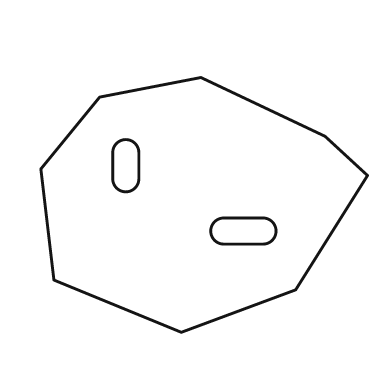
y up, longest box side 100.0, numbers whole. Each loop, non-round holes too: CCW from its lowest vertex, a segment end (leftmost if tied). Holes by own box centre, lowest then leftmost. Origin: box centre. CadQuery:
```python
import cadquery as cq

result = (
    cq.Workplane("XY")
    .moveTo(-7.0, -39.0)
    .lineTo(28.0, -26.0)
    .lineTo(50.0, 9.0)
    .lineTo(37.0, 21.0)
    .lineTo(-1.0, 39.0)
    .lineTo(-32.0, 33.0)
    .lineTo(-50.0, 11.0)
    .lineTo(-46.0, -23.0)
    .close()
    .moveTo(6.0, -12.0)
    .lineTo(18.0, -12.0)
    .threePointArc((22.0, -8.0), (18.0, -4.0))
    .lineTo(6.0, -4.0)
    .threePointArc((2.0, -8.0), (6.0, -12.0))
    .close()
    .moveTo(-28.0, 8.0)
    .threePointArc((-24.0, 4.0), (-20.0, 8.0))
    .lineTo(-20.0, 16.0)
    .threePointArc((-24.0, 20.0), (-28.0, 16.0))
    .close()
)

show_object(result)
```